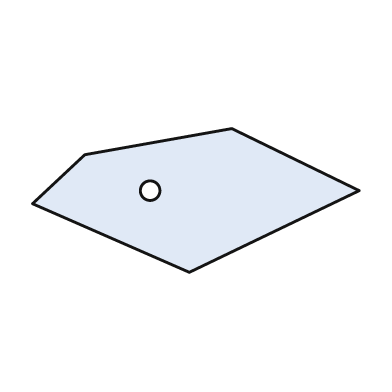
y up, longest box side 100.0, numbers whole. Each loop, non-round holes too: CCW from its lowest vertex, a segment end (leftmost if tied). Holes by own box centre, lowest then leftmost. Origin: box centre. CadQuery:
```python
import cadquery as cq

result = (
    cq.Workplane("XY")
    .moveTo(-2.0, -22.0)
    .lineTo(50.0, 3.0)
    .lineTo(11.0, 22.0)
    .lineTo(-34.0, 14.0)
    .lineTo(-50.0, -1.0)
    .close()
    .moveTo(-14.0, 3.0)
    .circle(3.0)
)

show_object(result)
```